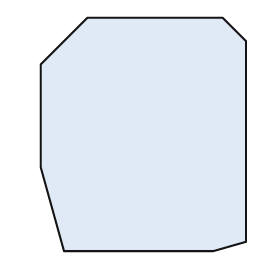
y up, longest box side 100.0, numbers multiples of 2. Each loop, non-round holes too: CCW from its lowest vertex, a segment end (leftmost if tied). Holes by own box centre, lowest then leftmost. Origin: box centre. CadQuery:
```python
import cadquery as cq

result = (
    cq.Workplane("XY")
    .moveTo(-34.0, -50.0)
    .lineTo(30.0, -50.0)
    .lineTo(44.0, -46.0)
    .lineTo(44.0, 40.0)
    .lineTo(34.0, 50.0)
    .lineTo(-24.0, 50.0)
    .lineTo(-44.0, 30.0)
    .lineTo(-44.0, -14.0)
    .close()
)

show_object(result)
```